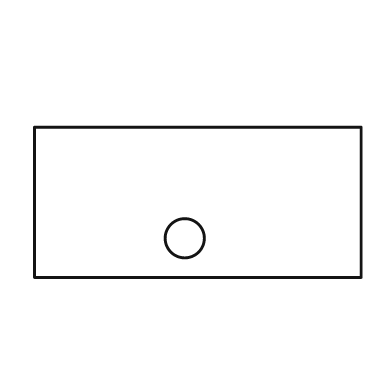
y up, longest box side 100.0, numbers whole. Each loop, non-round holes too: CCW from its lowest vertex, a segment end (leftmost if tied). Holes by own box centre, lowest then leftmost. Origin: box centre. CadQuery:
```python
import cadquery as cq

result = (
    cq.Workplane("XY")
    .moveTo(-50.0, -23.0)
    .lineTo(50.0, -23.0)
    .lineTo(50.0, 23.0)
    .lineTo(-50.0, 23.0)
    .close()
    .moveTo(-4.0, -11.0)
    .circle(6.0)
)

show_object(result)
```